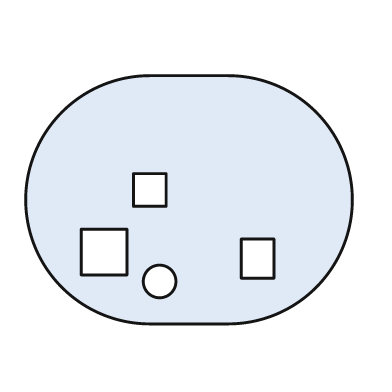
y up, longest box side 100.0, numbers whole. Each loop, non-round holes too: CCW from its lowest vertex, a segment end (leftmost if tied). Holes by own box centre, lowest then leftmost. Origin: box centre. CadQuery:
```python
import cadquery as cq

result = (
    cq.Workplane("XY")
    .moveTo(-12.0, -38.0)
    .lineTo(12.0, -38.0)
    .threePointArc((50.0, 0.0), (12.0, 38.0))
    .lineTo(-12.0, 38.0)
    .threePointArc((-50.0, 0.0), (-12.0, -38.0))
    .close()
    .moveTo(-9.0, -25.0)
    .circle(5.0)
    .moveTo(16.0, -24.0)
    .lineTo(26.0, -24.0)
    .lineTo(26.0, -12.0)
    .lineTo(16.0, -12.0)
    .close()
    .moveTo(-33.0, -23.0)
    .lineTo(-19.0, -23.0)
    .lineTo(-19.0, -9.0)
    .lineTo(-33.0, -9.0)
    .close()
    .moveTo(-17.0, -2.0)
    .lineTo(-7.0, -2.0)
    .lineTo(-7.0, 8.0)
    .lineTo(-17.0, 8.0)
    .close()
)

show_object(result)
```